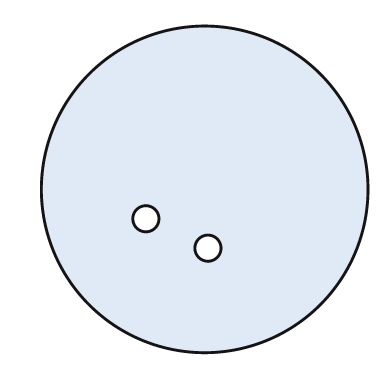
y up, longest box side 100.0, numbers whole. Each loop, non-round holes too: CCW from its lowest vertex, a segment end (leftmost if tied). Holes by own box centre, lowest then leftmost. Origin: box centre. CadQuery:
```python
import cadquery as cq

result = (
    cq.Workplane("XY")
    .moveTo(0.0, 0.0)
    .circle(50.0)
    .moveTo(1.0, -18.0)
    .circle(4.0)
    .moveTo(-18.0, -9.0)
    .circle(4.0)
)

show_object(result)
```